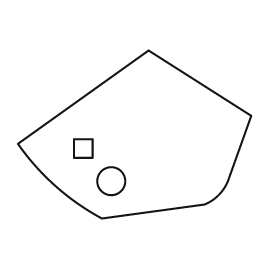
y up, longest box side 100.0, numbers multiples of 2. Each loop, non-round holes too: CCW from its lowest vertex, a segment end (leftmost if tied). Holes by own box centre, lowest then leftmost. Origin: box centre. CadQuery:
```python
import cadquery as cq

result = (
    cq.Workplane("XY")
    .moveTo(-14.0, -36.0)
    .lineTo(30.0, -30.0)
    .threePointArc((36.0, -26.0), (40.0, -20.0))
    .lineTo(50.0, 8.0)
    .lineTo(6.0, 36.0)
    .lineTo(-50.0, -4.0)
    .threePointArc((-34.0, -22.0), (-14.0, -36.0))
    .close()
    .moveTo(-10.0, -20.0)
    .circle(6.0)
    .moveTo(-26.0, -10.0)
    .lineTo(-18.0, -10.0)
    .lineTo(-18.0, -2.0)
    .lineTo(-26.0, -2.0)
    .close()
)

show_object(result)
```